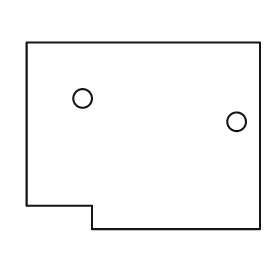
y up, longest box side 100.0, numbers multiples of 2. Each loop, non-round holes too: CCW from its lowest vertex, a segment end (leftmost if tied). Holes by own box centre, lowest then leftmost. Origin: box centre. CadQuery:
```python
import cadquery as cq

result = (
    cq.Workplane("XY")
    .moveTo(-22.0, -40.0)
    .lineTo(50.0, -40.0)
    .lineTo(50.0, 40.0)
    .lineTo(-50.0, 40.0)
    .lineTo(-50.0, -30.0)
    .lineTo(-22.0, -30.0)
    .close()
    .moveTo(40.0, 6.0)
    .circle(4.0)
    .moveTo(-26.0, 16.0)
    .circle(4.0)
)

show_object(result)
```